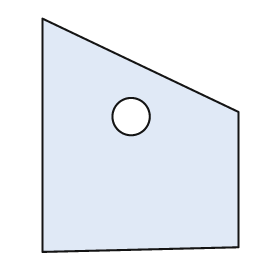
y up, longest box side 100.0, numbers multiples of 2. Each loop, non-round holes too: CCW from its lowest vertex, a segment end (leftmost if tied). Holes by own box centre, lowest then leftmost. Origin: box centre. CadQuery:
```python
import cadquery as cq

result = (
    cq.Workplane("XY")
    .moveTo(-42.0, -50.0)
    .lineTo(42.0, -48.0)
    .lineTo(42.0, 10.0)
    .lineTo(-42.0, 50.0)
    .close()
    .moveTo(-4.0, 8.0)
    .circle(8.0)
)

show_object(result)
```